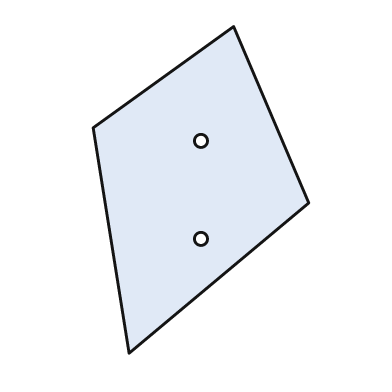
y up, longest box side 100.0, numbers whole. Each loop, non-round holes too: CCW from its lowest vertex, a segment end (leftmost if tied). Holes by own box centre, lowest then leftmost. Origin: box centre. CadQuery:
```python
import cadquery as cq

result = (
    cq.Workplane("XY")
    .moveTo(-22.0, -50.0)
    .lineTo(33.0, -4.0)
    .lineTo(10.0, 50.0)
    .lineTo(-33.0, 19.0)
    .close()
    .moveTo(0.0, -15.0)
    .circle(2.0)
    .moveTo(0.0, 15.0)
    .circle(2.0)
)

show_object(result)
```